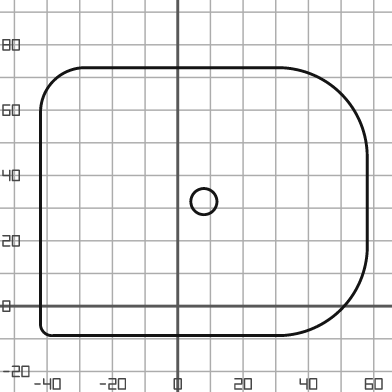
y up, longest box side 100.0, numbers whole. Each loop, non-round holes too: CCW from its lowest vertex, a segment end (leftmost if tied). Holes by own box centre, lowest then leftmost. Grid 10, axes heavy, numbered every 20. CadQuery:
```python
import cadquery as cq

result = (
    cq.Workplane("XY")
    .moveTo(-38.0, -9.0)
    .lineTo(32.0, -9.0)
    .threePointArc((50.0, -1.0), (58.0, 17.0))
    .lineTo(58.0, 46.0)
    .threePointArc((50.0, 65.0), (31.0, 73.0))
    .lineTo(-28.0, 73.0)
    .threePointArc((-38.0, 69.0), (-42.0, 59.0))
    .lineTo(-42.0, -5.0)
    .threePointArc((-41.0, -8.0), (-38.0, -9.0))
    .close()
    .moveTo(8.0, 32.0)
    .circle(4.0)
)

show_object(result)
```